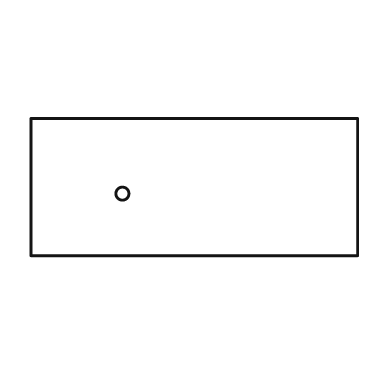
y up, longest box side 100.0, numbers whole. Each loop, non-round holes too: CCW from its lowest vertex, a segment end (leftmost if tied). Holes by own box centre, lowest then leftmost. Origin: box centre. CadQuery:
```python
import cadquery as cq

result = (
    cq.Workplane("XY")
    .moveTo(-50.0, -21.0)
    .lineTo(50.0, -21.0)
    .lineTo(50.0, 21.0)
    .lineTo(-50.0, 21.0)
    .close()
    .moveTo(-22.0, -2.0)
    .circle(2.0)
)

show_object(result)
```